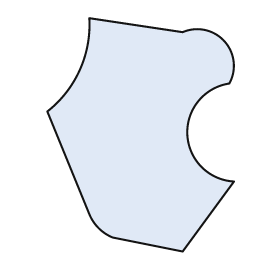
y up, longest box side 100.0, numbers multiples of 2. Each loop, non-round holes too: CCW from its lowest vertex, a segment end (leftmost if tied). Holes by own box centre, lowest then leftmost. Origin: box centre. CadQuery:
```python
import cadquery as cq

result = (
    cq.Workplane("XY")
    .moveTo(18.0, -50.0)
    .lineTo(40.0, -20.0)
    .threePointArc((20.0, 0.0), (38.0, 22.0))
    .threePointArc((36.0, 40.0), (18.0, 44.0))
    .lineTo(-22.0, 50.0)
    .threePointArc((-26.0, 28.0), (-40.0, 10.0))
    .lineTo(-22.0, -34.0)
    .threePointArc((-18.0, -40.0), (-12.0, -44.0))
    .close()
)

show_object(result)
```